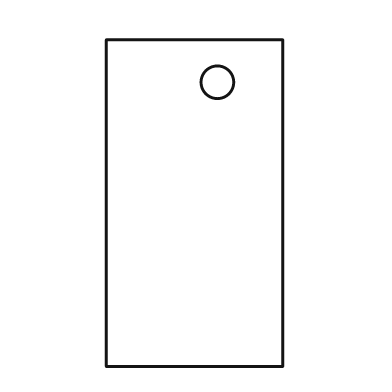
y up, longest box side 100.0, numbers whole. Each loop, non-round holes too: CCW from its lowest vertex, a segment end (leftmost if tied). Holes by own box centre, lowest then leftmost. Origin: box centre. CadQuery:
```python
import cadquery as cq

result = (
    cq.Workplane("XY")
    .moveTo(-27.0, -50.0)
    .lineTo(27.0, -50.0)
    .lineTo(27.0, 50.0)
    .lineTo(-27.0, 50.0)
    .close()
    .moveTo(7.0, 37.0)
    .circle(5.0)
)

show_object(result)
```